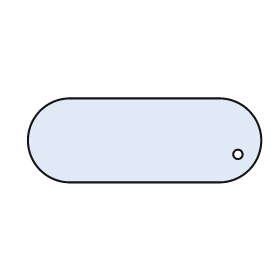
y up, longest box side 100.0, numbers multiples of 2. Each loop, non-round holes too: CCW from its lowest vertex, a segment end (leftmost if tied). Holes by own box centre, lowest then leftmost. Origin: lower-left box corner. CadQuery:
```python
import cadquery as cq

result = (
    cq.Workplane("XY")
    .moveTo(18.0, 0.0)
    .lineTo(82.0, 0.0)
    .threePointArc((100.0, 18.0), (82.0, 36.0))
    .lineTo(18.0, 36.0)
    .threePointArc((0.0, 18.0), (18.0, 0.0))
    .close()
    .moveTo(90.0, 12.0)
    .circle(2.0)
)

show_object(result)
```